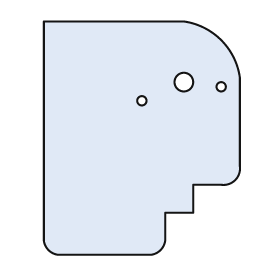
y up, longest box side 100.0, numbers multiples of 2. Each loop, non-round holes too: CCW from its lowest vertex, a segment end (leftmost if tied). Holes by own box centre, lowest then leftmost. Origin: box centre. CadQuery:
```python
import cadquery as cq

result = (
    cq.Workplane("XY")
    .moveTo(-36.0, -50.0)
    .lineTo(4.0, -50.0)
    .threePointArc((8.0, -48.0), (10.0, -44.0))
    .lineTo(10.0, -32.0)
    .lineTo(22.0, -32.0)
    .lineTo(22.0, -20.0)
    .lineTo(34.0, -20.0)
    .threePointArc((40.0, -18.0), (42.0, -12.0))
    .lineTo(42.0, 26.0)
    .threePointArc((34.0, 42.0), (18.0, 50.0))
    .lineTo(-42.0, 50.0)
    .lineTo(-42.0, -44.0)
    .threePointArc((-40.0, -48.0), (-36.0, -50.0))
    .close()
    .moveTo(0.0, 16.0)
    .circle(2.0)
    .moveTo(34.0, 22.0)
    .circle(2.0)
    .moveTo(18.0, 24.0)
    .circle(4.0)
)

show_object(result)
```